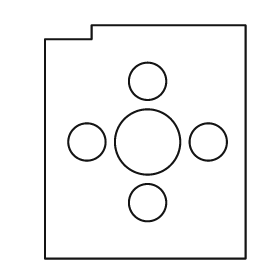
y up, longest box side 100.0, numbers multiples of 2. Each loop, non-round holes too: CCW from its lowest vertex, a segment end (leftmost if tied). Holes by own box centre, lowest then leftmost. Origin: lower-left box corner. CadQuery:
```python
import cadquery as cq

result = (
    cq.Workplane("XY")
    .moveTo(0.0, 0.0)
    .lineTo(86.0, 0.0)
    .lineTo(86.0, 100.0)
    .lineTo(20.0, 100.0)
    .lineTo(20.0, 94.0)
    .lineTo(0.0, 94.0)
    .close()
    .moveTo(44.0, 24.0)
    .circle(8.0)
    .moveTo(18.0, 50.0)
    .circle(8.0)
    .moveTo(44.0, 50.0)
    .circle(14.0)
    .moveTo(70.0, 50.0)
    .circle(8.0)
    .moveTo(44.0, 76.0)
    .circle(8.0)
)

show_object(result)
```